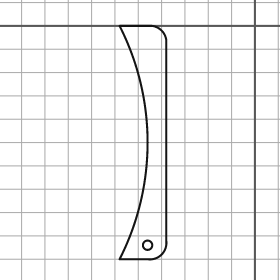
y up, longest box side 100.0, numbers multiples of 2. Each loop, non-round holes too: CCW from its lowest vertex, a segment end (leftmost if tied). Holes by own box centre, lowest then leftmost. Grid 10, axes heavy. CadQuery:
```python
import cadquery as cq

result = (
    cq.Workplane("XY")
    .moveTo(-58.0, -100.0)
    .lineTo(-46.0, -100.0)
    .threePointArc((-40.0, -98.0), (-38.0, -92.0))
    .lineTo(-38.0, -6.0)
    .threePointArc((-40.0, -2.0), (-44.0, 0.0))
    .lineTo(-58.0, 0.0)
    .threePointArc((-46.0, -50.0), (-58.0, -100.0))
    .close()
    .moveTo(-46.0, -94.0)
    .circle(2.0)
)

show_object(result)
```